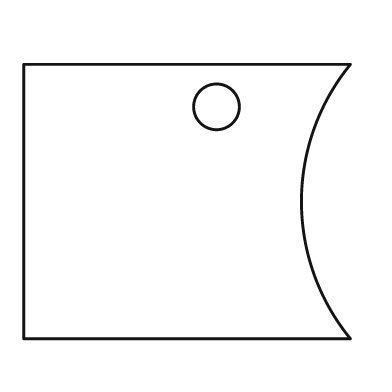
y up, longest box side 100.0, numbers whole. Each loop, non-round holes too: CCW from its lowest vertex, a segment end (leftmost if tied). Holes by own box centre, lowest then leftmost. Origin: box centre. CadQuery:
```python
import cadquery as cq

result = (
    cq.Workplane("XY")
    .moveTo(-50.0, -42.0)
    .lineTo(50.0, -42.0)
    .threePointArc((35.0, 0.0), (50.0, 42.0))
    .lineTo(-50.0, 42.0)
    .close()
    .moveTo(9.0, 29.0)
    .circle(7.0)
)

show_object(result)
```